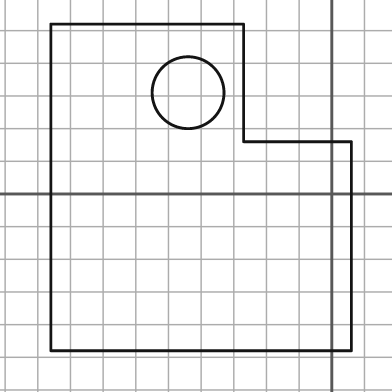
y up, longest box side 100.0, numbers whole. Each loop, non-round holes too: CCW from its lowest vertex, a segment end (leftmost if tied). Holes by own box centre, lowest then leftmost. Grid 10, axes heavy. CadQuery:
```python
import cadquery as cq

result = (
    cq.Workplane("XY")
    .moveTo(-86.0, -48.0)
    .lineTo(6.0, -48.0)
    .lineTo(6.0, 16.0)
    .lineTo(-27.0, 16.0)
    .lineTo(-27.0, 52.0)
    .lineTo(-86.0, 52.0)
    .close()
    .moveTo(-44.0, 31.0)
    .circle(11.0)
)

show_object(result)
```